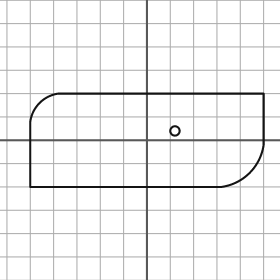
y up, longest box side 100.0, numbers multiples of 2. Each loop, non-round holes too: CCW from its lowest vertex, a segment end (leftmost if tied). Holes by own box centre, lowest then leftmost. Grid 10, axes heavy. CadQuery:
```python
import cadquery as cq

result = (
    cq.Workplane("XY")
    .moveTo(-50.0, -20.0)
    .lineTo(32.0, -20.0)
    .threePointArc((44.0, -14.0), (50.0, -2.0))
    .lineTo(50.0, 20.0)
    .lineTo(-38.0, 20.0)
    .threePointArc((-46.0, 16.0), (-50.0, 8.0))
    .close()
    .moveTo(12.0, 4.0)
    .circle(2.0)
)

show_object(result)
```